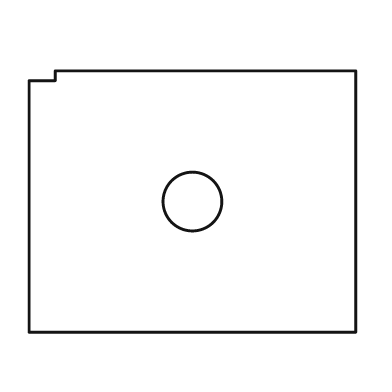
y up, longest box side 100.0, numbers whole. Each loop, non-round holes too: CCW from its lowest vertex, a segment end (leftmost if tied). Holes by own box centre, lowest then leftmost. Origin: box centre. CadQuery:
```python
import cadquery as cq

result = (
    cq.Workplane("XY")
    .moveTo(-50.0, -40.0)
    .lineTo(50.0, -40.0)
    .lineTo(50.0, 40.0)
    .lineTo(-42.0, 40.0)
    .lineTo(-42.0, 37.0)
    .lineTo(-50.0, 37.0)
    .close()
    .moveTo(0.0, 0.0)
    .circle(9.0)
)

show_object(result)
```